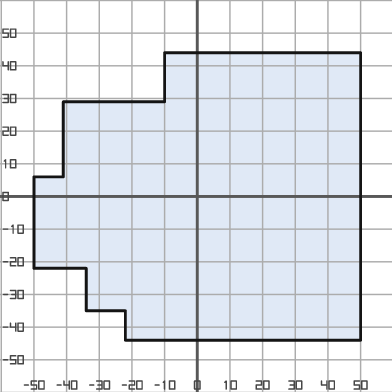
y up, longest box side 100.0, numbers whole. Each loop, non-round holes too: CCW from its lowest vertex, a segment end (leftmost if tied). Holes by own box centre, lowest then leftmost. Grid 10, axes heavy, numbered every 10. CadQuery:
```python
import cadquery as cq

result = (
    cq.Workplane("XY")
    .moveTo(-22.0, -44.0)
    .lineTo(50.0, -44.0)
    .lineTo(50.0, 44.0)
    .lineTo(-10.0, 44.0)
    .lineTo(-10.0, 29.0)
    .lineTo(-41.0, 29.0)
    .lineTo(-41.0, 6.0)
    .lineTo(-50.0, 6.0)
    .lineTo(-50.0, -22.0)
    .lineTo(-34.0, -22.0)
    .lineTo(-34.0, -35.0)
    .lineTo(-22.0, -35.0)
    .close()
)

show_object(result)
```